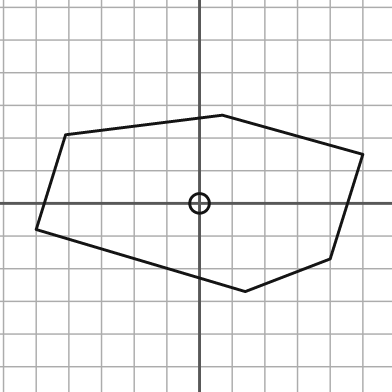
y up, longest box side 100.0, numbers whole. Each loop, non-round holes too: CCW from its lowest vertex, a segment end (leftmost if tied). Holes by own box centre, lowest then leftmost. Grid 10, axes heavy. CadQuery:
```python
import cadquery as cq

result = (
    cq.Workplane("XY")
    .moveTo(14.0, -27.0)
    .lineTo(40.0, -17.0)
    .lineTo(50.0, 15.0)
    .lineTo(7.0, 27.0)
    .lineTo(-41.0, 21.0)
    .lineTo(-50.0, -8.0)
    .close()
    .moveTo(0.0, 0.0)
    .circle(3.0)
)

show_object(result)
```